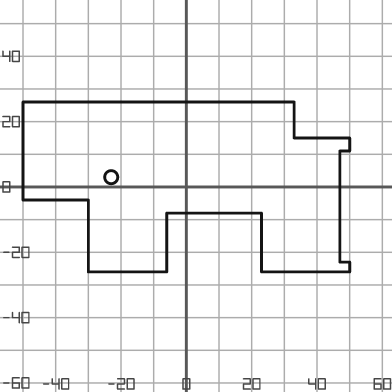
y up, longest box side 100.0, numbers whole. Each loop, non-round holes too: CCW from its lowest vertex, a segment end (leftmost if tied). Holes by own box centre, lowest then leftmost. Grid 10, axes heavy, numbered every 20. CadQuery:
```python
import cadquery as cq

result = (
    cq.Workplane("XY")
    .moveTo(-30.0, -26.0)
    .lineTo(-6.0, -26.0)
    .lineTo(-6.0, -8.0)
    .lineTo(23.0, -8.0)
    .lineTo(23.0, -26.0)
    .lineTo(50.0, -26.0)
    .lineTo(50.0, -23.0)
    .lineTo(47.0, -23.0)
    .lineTo(47.0, 11.0)
    .lineTo(50.0, 11.0)
    .lineTo(50.0, 15.0)
    .lineTo(33.0, 15.0)
    .lineTo(33.0, 26.0)
    .lineTo(-50.0, 26.0)
    .lineTo(-50.0, -4.0)
    .lineTo(-30.0, -4.0)
    .close()
    .moveTo(-23.0, 3.0)
    .circle(2.0)
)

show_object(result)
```